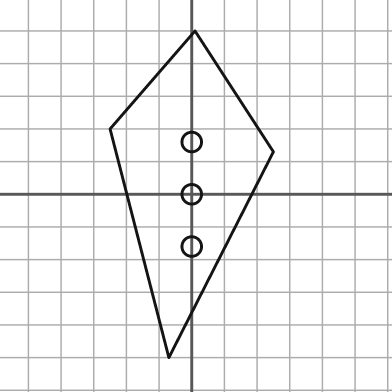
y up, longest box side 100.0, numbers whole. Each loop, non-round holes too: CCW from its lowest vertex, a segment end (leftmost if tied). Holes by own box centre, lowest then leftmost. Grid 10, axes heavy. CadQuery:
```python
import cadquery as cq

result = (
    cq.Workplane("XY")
    .moveTo(-7.0, -50.0)
    .lineTo(25.0, 13.0)
    .lineTo(1.0, 50.0)
    .lineTo(-25.0, 20.0)
    .close()
    .moveTo(0.0, -16.0)
    .circle(3.0)
    .moveTo(0.0, 0.0)
    .circle(3.0)
    .moveTo(0.0, 16.0)
    .circle(3.0)
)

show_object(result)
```